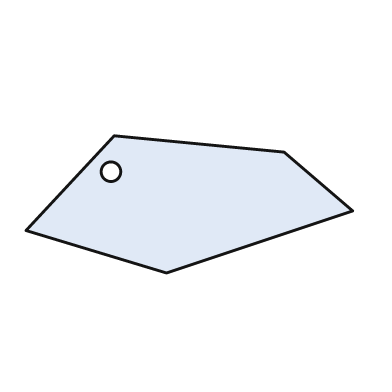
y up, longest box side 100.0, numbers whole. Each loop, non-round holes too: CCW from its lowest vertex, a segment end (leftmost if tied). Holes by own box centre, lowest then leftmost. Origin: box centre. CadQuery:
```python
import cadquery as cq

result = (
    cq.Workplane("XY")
    .moveTo(-7.0, -21.0)
    .lineTo(50.0, -2.0)
    .lineTo(29.0, 16.0)
    .lineTo(-23.0, 21.0)
    .lineTo(-50.0, -8.0)
    .close()
    .moveTo(-24.0, 10.0)
    .circle(3.0)
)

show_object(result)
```